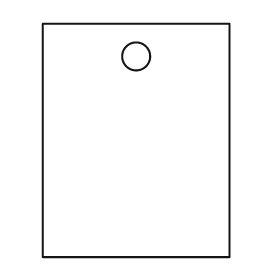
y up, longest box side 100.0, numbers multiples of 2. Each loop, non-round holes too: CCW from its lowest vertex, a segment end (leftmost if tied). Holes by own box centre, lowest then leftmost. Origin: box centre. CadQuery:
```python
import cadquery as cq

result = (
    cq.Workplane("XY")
    .moveTo(-40.0, -50.0)
    .lineTo(40.0, -50.0)
    .lineTo(40.0, 50.0)
    .lineTo(-40.0, 50.0)
    .close()
    .moveTo(0.0, 36.0)
    .circle(6.0)
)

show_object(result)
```